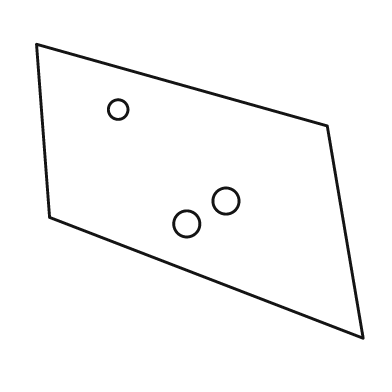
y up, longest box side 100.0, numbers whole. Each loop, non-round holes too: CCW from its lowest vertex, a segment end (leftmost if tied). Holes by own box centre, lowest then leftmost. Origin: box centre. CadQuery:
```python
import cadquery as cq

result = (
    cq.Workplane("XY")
    .moveTo(50.0, -45.0)
    .lineTo(39.0, 20.0)
    .lineTo(-50.0, 45.0)
    .lineTo(-46.0, -8.0)
    .close()
    .moveTo(-4.0, -10.0)
    .circle(4.0)
    .moveTo(8.0, -3.0)
    .circle(4.0)
    .moveTo(-25.0, 25.0)
    .circle(3.0)
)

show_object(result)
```